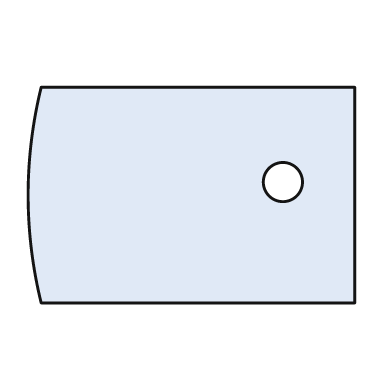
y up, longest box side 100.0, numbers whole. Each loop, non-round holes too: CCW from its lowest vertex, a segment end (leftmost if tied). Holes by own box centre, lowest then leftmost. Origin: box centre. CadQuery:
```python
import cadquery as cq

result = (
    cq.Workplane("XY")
    .moveTo(-46.0, -33.0)
    .lineTo(50.0, -33.0)
    .lineTo(50.0, 33.0)
    .lineTo(-46.0, 33.0)
    .threePointArc((-50.0, 0.0), (-46.0, -33.0))
    .close()
    .moveTo(28.0, 4.0)
    .circle(6.0)
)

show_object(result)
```